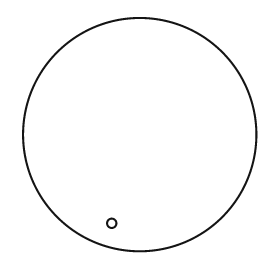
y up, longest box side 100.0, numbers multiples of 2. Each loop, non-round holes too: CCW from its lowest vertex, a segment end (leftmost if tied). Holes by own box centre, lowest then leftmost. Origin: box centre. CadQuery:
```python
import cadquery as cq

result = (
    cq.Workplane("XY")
    .moveTo(0.0, 0.0)
    .circle(50.0)
    .moveTo(-12.0, -38.0)
    .circle(2.0)
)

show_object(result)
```